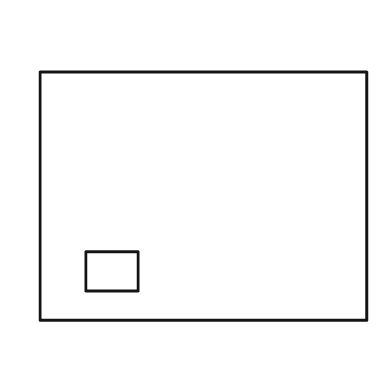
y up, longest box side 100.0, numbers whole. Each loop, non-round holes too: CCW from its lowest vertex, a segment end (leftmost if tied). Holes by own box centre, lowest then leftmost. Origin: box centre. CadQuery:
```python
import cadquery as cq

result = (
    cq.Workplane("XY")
    .moveTo(-50.0, -38.0)
    .lineTo(50.0, -38.0)
    .lineTo(50.0, 38.0)
    .lineTo(-50.0, 38.0)
    .close()
    .moveTo(-36.0, -29.0)
    .lineTo(-20.0, -29.0)
    .lineTo(-20.0, -17.0)
    .lineTo(-36.0, -17.0)
    .close()
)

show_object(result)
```